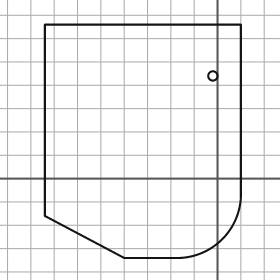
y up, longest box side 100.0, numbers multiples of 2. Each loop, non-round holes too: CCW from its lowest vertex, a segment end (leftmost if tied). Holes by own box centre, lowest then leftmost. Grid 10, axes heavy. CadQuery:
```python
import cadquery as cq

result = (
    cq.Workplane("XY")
    .moveTo(-40.0, -34.0)
    .lineTo(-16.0, -34.0)
    .threePointArc((2.0, -26.0), (10.0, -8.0))
    .lineTo(10.0, 66.0)
    .lineTo(-74.0, 66.0)
    .lineTo(-74.0, -16.0)
    .close()
    .moveTo(-2.0, 44.0)
    .circle(2.0)
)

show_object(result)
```